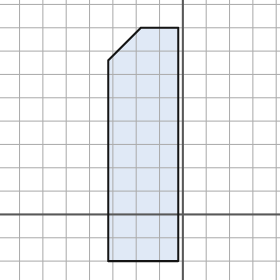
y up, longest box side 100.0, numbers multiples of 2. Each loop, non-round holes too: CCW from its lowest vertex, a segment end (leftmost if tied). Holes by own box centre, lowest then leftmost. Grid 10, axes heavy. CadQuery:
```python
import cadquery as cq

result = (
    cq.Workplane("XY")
    .moveTo(-32.0, -20.0)
    .lineTo(-2.0, -20.0)
    .lineTo(-2.0, 80.0)
    .lineTo(-18.0, 80.0)
    .lineTo(-32.0, 66.0)
    .close()
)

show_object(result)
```